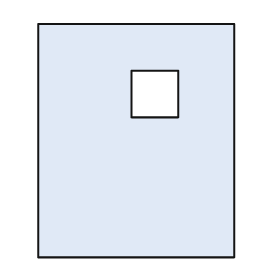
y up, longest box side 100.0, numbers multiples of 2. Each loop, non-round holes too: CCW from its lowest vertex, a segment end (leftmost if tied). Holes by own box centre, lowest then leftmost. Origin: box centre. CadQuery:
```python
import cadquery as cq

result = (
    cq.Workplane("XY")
    .moveTo(-42.0, -50.0)
    .lineTo(42.0, -50.0)
    .lineTo(42.0, 50.0)
    .lineTo(-42.0, 50.0)
    .close()
    .moveTo(-2.0, 10.0)
    .lineTo(18.0, 10.0)
    .lineTo(18.0, 30.0)
    .lineTo(-2.0, 30.0)
    .close()
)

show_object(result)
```